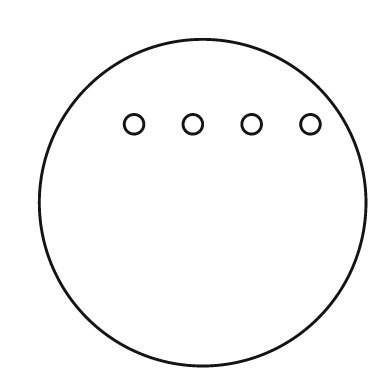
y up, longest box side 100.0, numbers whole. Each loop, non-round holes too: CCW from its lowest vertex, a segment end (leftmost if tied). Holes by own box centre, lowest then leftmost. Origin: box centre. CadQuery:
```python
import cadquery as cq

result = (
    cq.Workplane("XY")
    .moveTo(0.0, 0.0)
    .circle(50.0)
    .moveTo(-21.0, 24.0)
    .circle(3.0)
    .moveTo(-3.0, 24.0)
    .circle(3.0)
    .moveTo(15.0, 24.0)
    .circle(3.0)
    .moveTo(33.0, 24.0)
    .circle(3.0)
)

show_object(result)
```